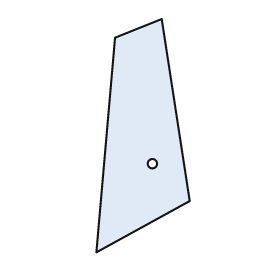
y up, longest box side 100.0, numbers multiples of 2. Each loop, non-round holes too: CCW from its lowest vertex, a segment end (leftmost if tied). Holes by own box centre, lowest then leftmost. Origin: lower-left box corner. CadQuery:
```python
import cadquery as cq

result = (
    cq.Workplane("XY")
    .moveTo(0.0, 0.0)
    .lineTo(40.0, 22.0)
    .lineTo(28.0, 100.0)
    .lineTo(8.0, 92.0)
    .close()
    .moveTo(24.0, 38.0)
    .circle(2.0)
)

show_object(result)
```